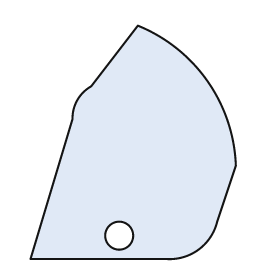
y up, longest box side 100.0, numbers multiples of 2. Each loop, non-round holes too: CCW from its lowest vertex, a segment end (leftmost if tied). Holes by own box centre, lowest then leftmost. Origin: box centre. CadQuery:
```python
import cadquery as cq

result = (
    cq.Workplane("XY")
    .moveTo(-44.0, -50.0)
    .lineTo(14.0, -50.0)
    .threePointArc((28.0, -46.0), (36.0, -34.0))
    .lineTo(44.0, -10.0)
    .threePointArc((32.0, 26.0), (2.0, 50.0))
    .lineTo(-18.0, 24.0)
    .threePointArc((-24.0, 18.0), (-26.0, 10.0))
    .close()
    .moveTo(-6.0, -40.0)
    .circle(6.0)
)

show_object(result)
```